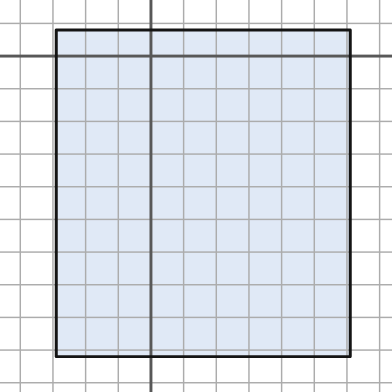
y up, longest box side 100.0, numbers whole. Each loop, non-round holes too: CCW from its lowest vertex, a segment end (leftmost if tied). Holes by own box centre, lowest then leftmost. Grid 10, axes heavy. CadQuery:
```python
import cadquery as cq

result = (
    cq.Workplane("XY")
    .moveTo(-29.0, -92.0)
    .lineTo(61.0, -92.0)
    .lineTo(61.0, 8.0)
    .lineTo(-29.0, 8.0)
    .close()
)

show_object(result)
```